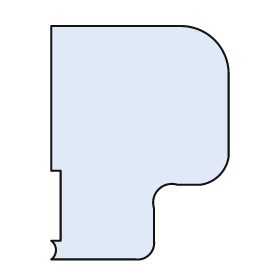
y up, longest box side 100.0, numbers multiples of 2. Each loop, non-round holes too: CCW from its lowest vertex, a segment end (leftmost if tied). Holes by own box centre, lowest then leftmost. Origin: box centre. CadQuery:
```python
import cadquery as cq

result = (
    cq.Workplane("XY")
    .moveTo(-38.0, -50.0)
    .lineTo(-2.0, -50.0)
    .threePointArc((4.0, -48.0), (6.0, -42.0))
    .lineTo(6.0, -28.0)
    .threePointArc((8.0, -20.0), (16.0, -18.0))
    .lineTo(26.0, -18.0)
    .threePointArc((34.0, -14.0), (38.0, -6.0))
    .lineTo(38.0, 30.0)
    .threePointArc((32.0, 44.0), (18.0, 50.0))
    .lineTo(-38.0, 50.0)
    .lineTo(-38.0, -12.0)
    .lineTo(-34.0, -12.0)
    .lineTo(-34.0, -42.0)
    .lineTo(-38.0, -42.0)
    .threePointArc((-36.0, -46.0), (-38.0, -50.0))
    .close()
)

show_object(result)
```